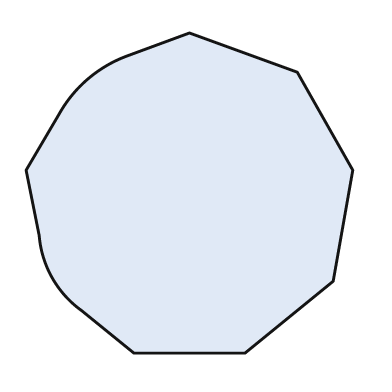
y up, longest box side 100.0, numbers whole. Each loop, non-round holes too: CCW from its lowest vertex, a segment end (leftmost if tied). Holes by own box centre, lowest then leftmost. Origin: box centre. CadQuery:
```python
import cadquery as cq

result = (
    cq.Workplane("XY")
    .moveTo(-17.0, -49.0)
    .lineTo(17.0, -49.0)
    .lineTo(44.0, -27.0)
    .lineTo(50.0, 7.0)
    .lineTo(33.0, 37.0)
    .lineTo(0.0, 49.0)
    .lineTo(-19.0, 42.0)
    .threePointArc((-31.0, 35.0), (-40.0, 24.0))
    .lineTo(-50.0, 7.0)
    .lineTo(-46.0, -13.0)
    .threePointArc((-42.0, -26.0), (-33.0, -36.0))
    .close()
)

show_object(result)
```